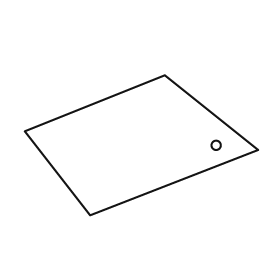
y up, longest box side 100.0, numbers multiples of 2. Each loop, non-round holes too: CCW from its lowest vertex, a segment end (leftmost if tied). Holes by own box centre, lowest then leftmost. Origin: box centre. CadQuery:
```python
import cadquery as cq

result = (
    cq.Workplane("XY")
    .moveTo(-22.0, -30.0)
    .lineTo(50.0, -2.0)
    .lineTo(10.0, 30.0)
    .lineTo(-50.0, 6.0)
    .close()
    .moveTo(32.0, 0.0)
    .circle(2.0)
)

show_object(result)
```